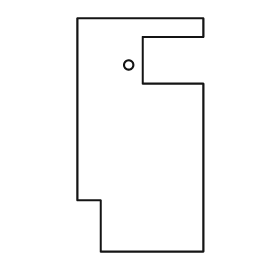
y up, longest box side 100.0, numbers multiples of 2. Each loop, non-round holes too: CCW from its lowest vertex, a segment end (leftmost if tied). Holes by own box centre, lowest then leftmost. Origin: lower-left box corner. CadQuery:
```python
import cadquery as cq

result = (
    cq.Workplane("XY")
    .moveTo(10.0, 0.0)
    .lineTo(54.0, 0.0)
    .lineTo(54.0, 72.0)
    .lineTo(28.0, 72.0)
    .lineTo(28.0, 92.0)
    .lineTo(54.0, 92.0)
    .lineTo(54.0, 100.0)
    .lineTo(0.0, 100.0)
    .lineTo(0.0, 22.0)
    .lineTo(10.0, 22.0)
    .close()
    .moveTo(22.0, 80.0)
    .circle(2.0)
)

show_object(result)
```